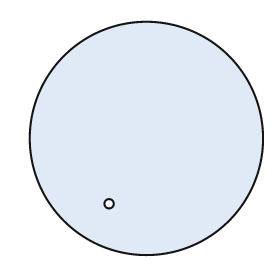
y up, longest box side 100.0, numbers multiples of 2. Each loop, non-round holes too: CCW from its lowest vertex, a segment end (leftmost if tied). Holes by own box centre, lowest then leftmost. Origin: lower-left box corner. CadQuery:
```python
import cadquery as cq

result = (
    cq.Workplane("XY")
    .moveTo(50.0, 50.0)
    .circle(50.0)
    .moveTo(34.0, 22.0)
    .circle(2.0)
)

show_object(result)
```